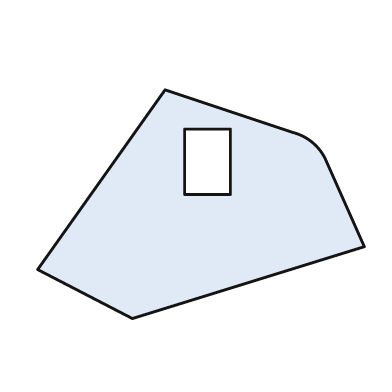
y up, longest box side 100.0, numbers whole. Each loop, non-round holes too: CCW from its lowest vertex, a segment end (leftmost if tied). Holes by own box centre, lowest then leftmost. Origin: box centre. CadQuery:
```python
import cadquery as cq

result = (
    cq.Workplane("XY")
    .moveTo(-21.0, -35.0)
    .lineTo(50.0, -13.0)
    .lineTo(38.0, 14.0)
    .threePointArc((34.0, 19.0), (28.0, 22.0))
    .lineTo(-11.0, 35.0)
    .lineTo(-50.0, -20.0)
    .close()
    .moveTo(-5.0, 3.0)
    .lineTo(9.0, 3.0)
    .lineTo(9.0, 23.0)
    .lineTo(-5.0, 23.0)
    .close()
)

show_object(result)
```